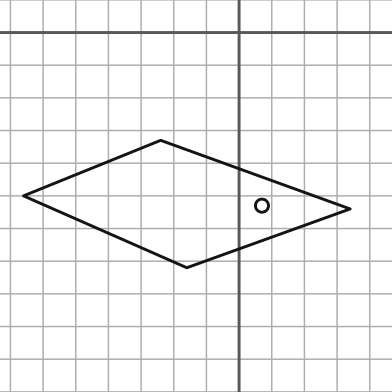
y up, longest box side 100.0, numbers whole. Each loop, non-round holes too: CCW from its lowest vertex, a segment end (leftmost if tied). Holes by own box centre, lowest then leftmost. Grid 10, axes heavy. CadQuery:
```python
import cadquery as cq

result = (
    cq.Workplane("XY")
    .moveTo(-16.0, -72.0)
    .lineTo(34.0, -54.0)
    .lineTo(-24.0, -33.0)
    .lineTo(-66.0, -50.0)
    .close()
    .moveTo(7.0, -53.0)
    .circle(2.0)
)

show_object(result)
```